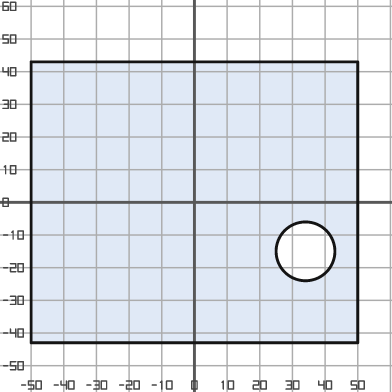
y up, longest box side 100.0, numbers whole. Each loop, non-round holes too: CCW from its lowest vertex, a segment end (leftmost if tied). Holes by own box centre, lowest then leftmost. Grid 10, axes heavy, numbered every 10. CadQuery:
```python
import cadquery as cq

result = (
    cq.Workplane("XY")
    .moveTo(-50.0, -43.0)
    .lineTo(50.0, -43.0)
    .lineTo(50.0, 43.0)
    .lineTo(-50.0, 43.0)
    .close()
    .moveTo(34.0, -15.0)
    .circle(9.0)
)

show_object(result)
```